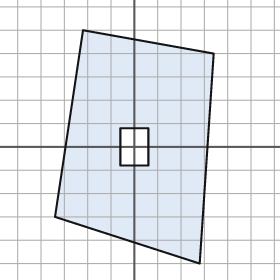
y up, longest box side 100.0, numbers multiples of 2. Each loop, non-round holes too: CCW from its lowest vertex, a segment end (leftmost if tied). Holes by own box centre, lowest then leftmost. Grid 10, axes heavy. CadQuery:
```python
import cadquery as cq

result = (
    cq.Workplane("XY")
    .moveTo(28.0, -50.0)
    .lineTo(34.0, 40.0)
    .lineTo(-22.0, 50.0)
    .lineTo(-34.0, -30.0)
    .close()
    .moveTo(-6.0, -8.0)
    .lineTo(6.0, -8.0)
    .lineTo(6.0, 8.0)
    .lineTo(-6.0, 8.0)
    .close()
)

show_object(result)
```